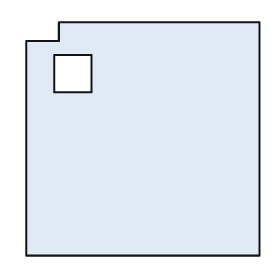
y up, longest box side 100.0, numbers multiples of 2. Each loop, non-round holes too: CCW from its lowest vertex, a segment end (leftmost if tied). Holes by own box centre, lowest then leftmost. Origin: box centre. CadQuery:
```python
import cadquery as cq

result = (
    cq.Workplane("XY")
    .moveTo(-50.0, -50.0)
    .lineTo(50.0, -50.0)
    .lineTo(50.0, 50.0)
    .lineTo(-36.0, 50.0)
    .lineTo(-36.0, 42.0)
    .lineTo(-50.0, 42.0)
    .close()
    .moveTo(-38.0, 20.0)
    .lineTo(-22.0, 20.0)
    .lineTo(-22.0, 36.0)
    .lineTo(-38.0, 36.0)
    .close()
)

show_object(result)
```